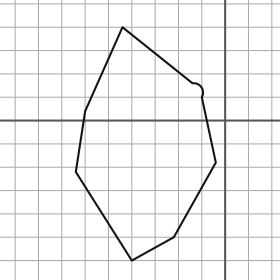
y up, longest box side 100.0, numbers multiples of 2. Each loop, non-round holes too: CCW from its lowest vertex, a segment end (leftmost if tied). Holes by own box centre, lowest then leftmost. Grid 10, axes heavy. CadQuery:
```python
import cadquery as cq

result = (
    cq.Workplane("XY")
    .moveTo(-40.0, -60.0)
    .lineTo(-22.0, -50.0)
    .lineTo(-4.0, -18.0)
    .lineTo(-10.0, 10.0)
    .threePointArc((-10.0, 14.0), (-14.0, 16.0))
    .lineTo(-44.0, 40.0)
    .lineTo(-60.0, 4.0)
    .lineTo(-64.0, -22.0)
    .close()
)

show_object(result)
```